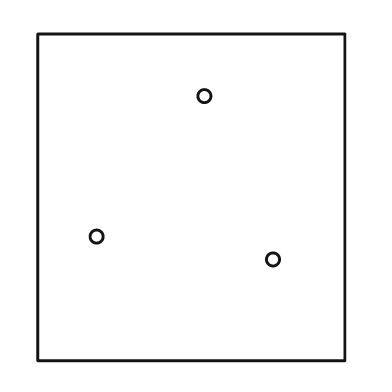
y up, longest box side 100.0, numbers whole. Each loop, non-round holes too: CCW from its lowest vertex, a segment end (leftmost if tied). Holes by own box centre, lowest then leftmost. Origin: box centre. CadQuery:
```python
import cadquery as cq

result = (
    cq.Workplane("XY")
    .moveTo(-47.0, -50.0)
    .lineTo(47.0, -50.0)
    .lineTo(47.0, 50.0)
    .lineTo(-47.0, 50.0)
    .close()
    .moveTo(25.0, -19.0)
    .circle(2.0)
    .moveTo(-29.0, -12.0)
    .circle(2.0)
    .moveTo(4.0, 31.0)
    .circle(2.0)
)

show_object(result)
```